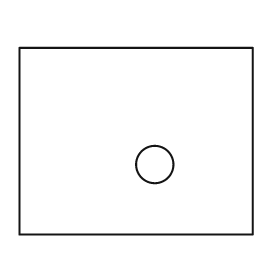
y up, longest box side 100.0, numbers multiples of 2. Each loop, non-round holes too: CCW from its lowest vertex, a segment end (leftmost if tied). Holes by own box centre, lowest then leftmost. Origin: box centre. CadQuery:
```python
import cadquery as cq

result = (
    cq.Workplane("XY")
    .moveTo(-50.0, -40.0)
    .lineTo(50.0, -40.0)
    .lineTo(50.0, 40.0)
    .lineTo(-50.0, 40.0)
    .close()
    .moveTo(8.0, -10.0)
    .circle(8.0)
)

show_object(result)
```